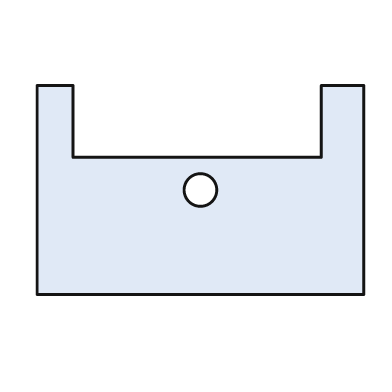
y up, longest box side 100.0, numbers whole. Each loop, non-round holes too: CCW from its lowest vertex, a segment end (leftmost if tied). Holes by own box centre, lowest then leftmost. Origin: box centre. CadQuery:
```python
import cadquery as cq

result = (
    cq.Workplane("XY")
    .moveTo(-50.0, -32.0)
    .lineTo(50.0, -32.0)
    .lineTo(50.0, 32.0)
    .lineTo(37.0, 32.0)
    .lineTo(37.0, 10.0)
    .lineTo(-39.0, 10.0)
    .lineTo(-39.0, 32.0)
    .lineTo(-50.0, 32.0)
    .close()
    .moveTo(0.0, 0.0)
    .circle(5.0)
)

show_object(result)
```